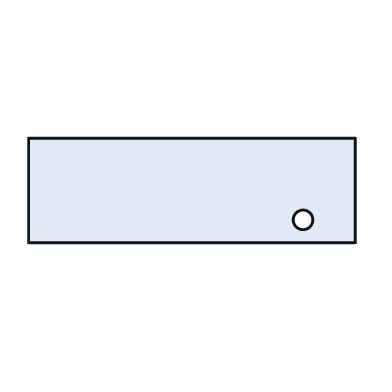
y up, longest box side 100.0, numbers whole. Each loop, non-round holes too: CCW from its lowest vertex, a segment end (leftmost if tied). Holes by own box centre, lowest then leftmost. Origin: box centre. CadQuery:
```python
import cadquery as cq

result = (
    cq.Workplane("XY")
    .moveTo(-50.0, -16.0)
    .lineTo(50.0, -16.0)
    .lineTo(50.0, 16.0)
    .lineTo(-50.0, 16.0)
    .close()
    .moveTo(34.0, -9.0)
    .circle(3.0)
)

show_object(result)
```